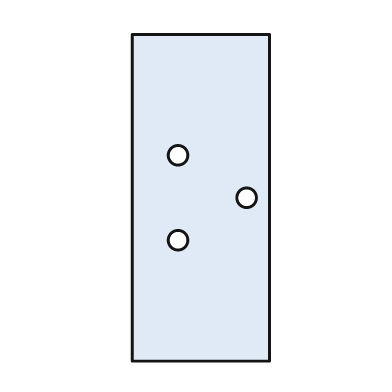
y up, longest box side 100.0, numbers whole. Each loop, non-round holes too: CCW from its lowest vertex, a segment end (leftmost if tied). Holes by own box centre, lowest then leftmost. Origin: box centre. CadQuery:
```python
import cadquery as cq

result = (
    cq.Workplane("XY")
    .moveTo(-21.0, -50.0)
    .lineTo(21.0, -50.0)
    .lineTo(21.0, 50.0)
    .lineTo(-21.0, 50.0)
    .close()
    .moveTo(-7.0, -13.0)
    .circle(3.0)
    .moveTo(14.0, 0.0)
    .circle(3.0)
    .moveTo(-7.0, 13.0)
    .circle(3.0)
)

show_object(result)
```